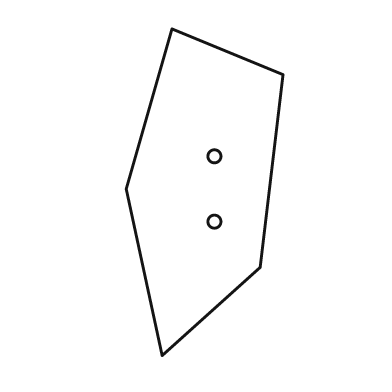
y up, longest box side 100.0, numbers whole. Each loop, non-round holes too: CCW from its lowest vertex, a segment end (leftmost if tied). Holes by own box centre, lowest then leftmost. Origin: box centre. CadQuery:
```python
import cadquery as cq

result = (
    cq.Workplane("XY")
    .moveTo(-13.0, -50.0)
    .lineTo(17.0, -23.0)
    .lineTo(24.0, 36.0)
    .lineTo(-10.0, 50.0)
    .lineTo(-24.0, 1.0)
    .close()
    .moveTo(3.0, -9.0)
    .circle(2.0)
    .moveTo(3.0, 11.0)
    .circle(2.0)
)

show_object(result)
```